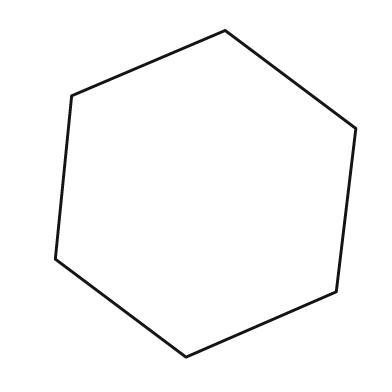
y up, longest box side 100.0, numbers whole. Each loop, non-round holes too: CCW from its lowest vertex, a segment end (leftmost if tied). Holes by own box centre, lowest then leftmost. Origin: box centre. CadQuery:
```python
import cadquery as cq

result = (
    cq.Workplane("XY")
    .moveTo(-6.0, -50.0)
    .lineTo(40.0, -30.0)
    .lineTo(46.0, 20.0)
    .lineTo(6.0, 50.0)
    .lineTo(-41.0, 30.0)
    .lineTo(-46.0, -20.0)
    .close()
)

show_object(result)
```